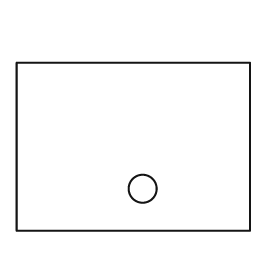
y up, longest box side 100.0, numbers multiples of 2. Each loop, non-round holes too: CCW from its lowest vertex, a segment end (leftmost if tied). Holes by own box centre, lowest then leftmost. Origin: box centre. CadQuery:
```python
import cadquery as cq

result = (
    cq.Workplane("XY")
    .moveTo(-50.0, -36.0)
    .lineTo(50.0, -36.0)
    .lineTo(50.0, 36.0)
    .lineTo(-50.0, 36.0)
    .close()
    .moveTo(4.0, -18.0)
    .circle(6.0)
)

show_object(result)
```